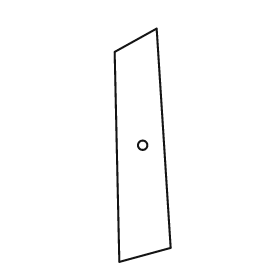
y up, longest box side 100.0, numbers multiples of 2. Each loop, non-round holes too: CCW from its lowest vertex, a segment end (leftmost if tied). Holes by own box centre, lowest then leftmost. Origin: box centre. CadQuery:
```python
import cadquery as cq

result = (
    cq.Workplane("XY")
    .moveTo(-10.0, -50.0)
    .lineTo(12.0, -44.0)
    .lineTo(6.0, 50.0)
    .lineTo(-12.0, 40.0)
    .close()
    .moveTo(0.0, 0.0)
    .circle(2.0)
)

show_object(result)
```